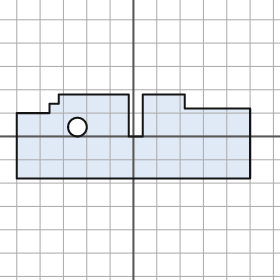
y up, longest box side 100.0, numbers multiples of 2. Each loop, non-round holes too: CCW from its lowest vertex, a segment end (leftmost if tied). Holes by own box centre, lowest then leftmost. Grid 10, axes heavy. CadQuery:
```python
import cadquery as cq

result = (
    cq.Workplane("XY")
    .moveTo(-50.0, -18.0)
    .lineTo(50.0, -18.0)
    .lineTo(50.0, 12.0)
    .lineTo(22.0, 12.0)
    .lineTo(22.0, 18.0)
    .lineTo(4.0, 18.0)
    .lineTo(4.0, 0.0)
    .lineTo(-2.0, 0.0)
    .lineTo(-2.0, 18.0)
    .lineTo(-32.0, 18.0)
    .lineTo(-32.0, 14.0)
    .lineTo(-36.0, 14.0)
    .lineTo(-36.0, 10.0)
    .lineTo(-50.0, 10.0)
    .close()
    .moveTo(-24.0, 4.0)
    .circle(4.0)
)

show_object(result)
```